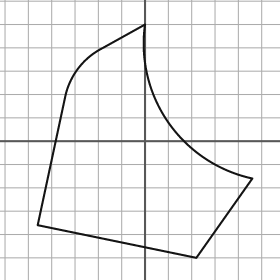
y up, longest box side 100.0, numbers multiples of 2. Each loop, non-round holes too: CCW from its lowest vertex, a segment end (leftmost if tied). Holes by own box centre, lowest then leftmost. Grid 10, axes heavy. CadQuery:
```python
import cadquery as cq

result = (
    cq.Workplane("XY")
    .moveTo(22.0, -50.0)
    .lineTo(46.0, -16.0)
    .threePointArc((10.0, 8.0), (0.0, 50.0))
    .lineTo(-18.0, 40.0)
    .threePointArc((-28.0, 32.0), (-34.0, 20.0))
    .lineTo(-46.0, -36.0)
    .close()
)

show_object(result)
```